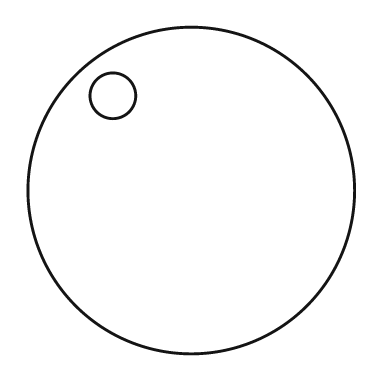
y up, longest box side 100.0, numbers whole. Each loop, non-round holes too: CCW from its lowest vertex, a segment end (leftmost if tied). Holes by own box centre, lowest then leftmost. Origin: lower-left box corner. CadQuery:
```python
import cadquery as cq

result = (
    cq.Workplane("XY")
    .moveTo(50.0, 50.0)
    .circle(50.0)
    .moveTo(26.0, 79.0)
    .circle(7.0)
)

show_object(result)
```